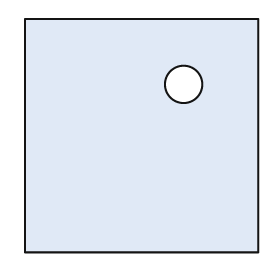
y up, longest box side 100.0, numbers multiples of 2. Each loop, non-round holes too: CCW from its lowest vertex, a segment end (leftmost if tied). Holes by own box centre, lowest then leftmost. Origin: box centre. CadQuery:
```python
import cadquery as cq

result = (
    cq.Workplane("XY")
    .moveTo(-50.0, -50.0)
    .lineTo(50.0, -50.0)
    .lineTo(50.0, 50.0)
    .lineTo(-50.0, 50.0)
    .close()
    .moveTo(18.0, 22.0)
    .circle(8.0)
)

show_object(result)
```